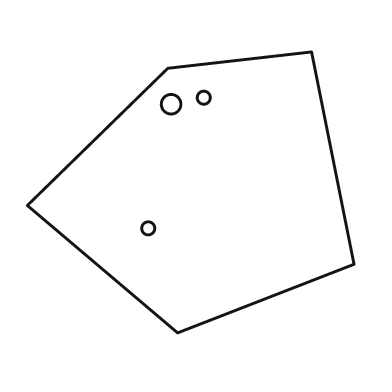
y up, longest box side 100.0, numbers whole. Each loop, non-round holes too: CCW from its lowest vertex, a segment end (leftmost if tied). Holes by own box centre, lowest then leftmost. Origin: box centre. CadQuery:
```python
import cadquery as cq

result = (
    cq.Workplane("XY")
    .moveTo(-4.0, -43.0)
    .lineTo(50.0, -22.0)
    .lineTo(37.0, 43.0)
    .lineTo(-7.0, 38.0)
    .lineTo(-50.0, -4.0)
    .close()
    .moveTo(-13.0, -11.0)
    .circle(2.0)
    .moveTo(-6.0, 27.0)
    .circle(3.0)
    .moveTo(4.0, 29.0)
    .circle(2.0)
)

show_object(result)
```